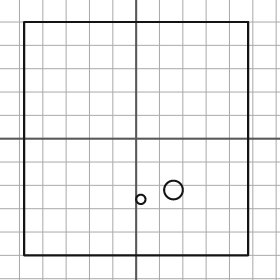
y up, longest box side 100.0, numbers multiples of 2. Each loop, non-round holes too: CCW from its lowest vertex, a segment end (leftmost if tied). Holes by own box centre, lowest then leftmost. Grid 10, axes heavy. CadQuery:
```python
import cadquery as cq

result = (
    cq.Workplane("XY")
    .moveTo(-48.0, -50.0)
    .lineTo(48.0, -50.0)
    .lineTo(48.0, 50.0)
    .lineTo(-48.0, 50.0)
    .close()
    .moveTo(2.0, -26.0)
    .circle(2.0)
    .moveTo(16.0, -22.0)
    .circle(4.0)
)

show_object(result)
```